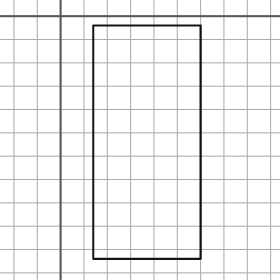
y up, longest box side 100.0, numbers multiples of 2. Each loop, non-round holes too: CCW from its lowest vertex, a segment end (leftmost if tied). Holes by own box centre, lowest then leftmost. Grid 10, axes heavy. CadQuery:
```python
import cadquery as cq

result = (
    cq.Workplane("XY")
    .moveTo(14.0, -104.0)
    .lineTo(60.0, -104.0)
    .lineTo(60.0, -4.0)
    .lineTo(14.0, -4.0)
    .close()
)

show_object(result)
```